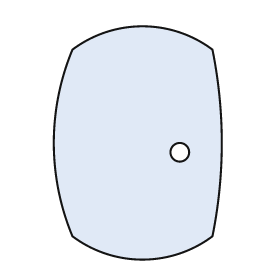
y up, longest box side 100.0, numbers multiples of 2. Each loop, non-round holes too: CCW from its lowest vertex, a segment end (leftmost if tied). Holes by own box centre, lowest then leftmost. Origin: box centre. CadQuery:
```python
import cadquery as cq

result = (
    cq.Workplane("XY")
    .moveTo(-28.0, -40.0)
    .threePointArc((2.0, -50.0), (32.0, -40.0))
    .threePointArc((36.0, 0.0), (32.0, 40.0))
    .threePointArc((2.0, 50.0), (-28.0, 40.0))
    .threePointArc((-36.0, 0.0), (-28.0, -40.0))
    .close()
    .moveTo(18.0, -4.0)
    .circle(4.0)
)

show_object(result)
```